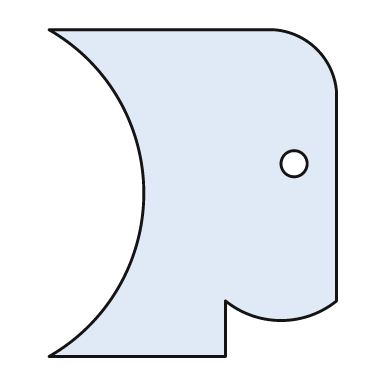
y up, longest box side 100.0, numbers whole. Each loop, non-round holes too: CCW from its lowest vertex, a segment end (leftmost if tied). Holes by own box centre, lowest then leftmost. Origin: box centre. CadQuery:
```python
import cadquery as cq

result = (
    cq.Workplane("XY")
    .moveTo(-44.0, -50.0)
    .lineTo(10.0, -50.0)
    .lineTo(10.0, -33.0)
    .threePointArc((27.0, -39.0), (44.0, -33.0))
    .lineTo(44.0, 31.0)
    .threePointArc((38.0, 44.0), (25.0, 50.0))
    .lineTo(-44.0, 50.0)
    .threePointArc((-15.0, 0.0), (-44.0, -50.0))
    .close()
    .moveTo(31.0, 9.0)
    .circle(4.0)
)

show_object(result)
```